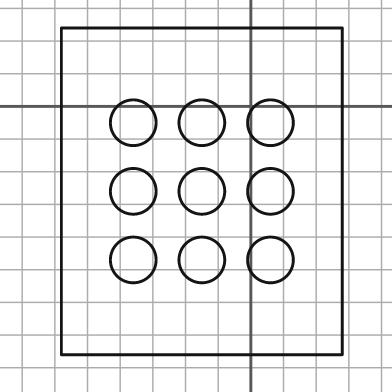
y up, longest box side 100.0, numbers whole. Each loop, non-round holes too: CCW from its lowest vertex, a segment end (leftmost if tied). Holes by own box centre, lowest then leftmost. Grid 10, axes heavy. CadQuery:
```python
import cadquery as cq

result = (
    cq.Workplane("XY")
    .moveTo(-58.0, -76.0)
    .lineTo(28.0, -76.0)
    .lineTo(28.0, 24.0)
    .lineTo(-58.0, 24.0)
    .close()
    .moveTo(-36.0, -47.0)
    .circle(7.0)
    .moveTo(-15.0, -47.0)
    .circle(7.0)
    .moveTo(6.0, -47.0)
    .circle(7.0)
    .moveTo(-36.0, -26.0)
    .circle(7.0)
    .moveTo(-15.0, -26.0)
    .circle(7.0)
    .moveTo(6.0, -26.0)
    .circle(7.0)
    .moveTo(-36.0, -5.0)
    .circle(7.0)
    .moveTo(-15.0, -5.0)
    .circle(7.0)
    .moveTo(6.0, -5.0)
    .circle(7.0)
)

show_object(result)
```